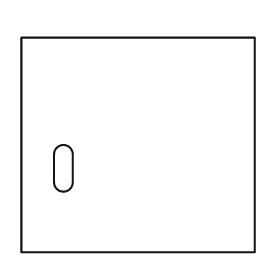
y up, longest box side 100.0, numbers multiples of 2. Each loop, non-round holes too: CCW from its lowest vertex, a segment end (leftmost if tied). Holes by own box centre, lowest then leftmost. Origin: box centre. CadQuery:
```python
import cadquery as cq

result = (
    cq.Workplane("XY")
    .moveTo(-50.0, -46.0)
    .lineTo(50.0, -46.0)
    .lineTo(50.0, 46.0)
    .lineTo(-50.0, 46.0)
    .close()
    .moveTo(-36.0, -16.0)
    .threePointArc((-32.0, -20.0), (-28.0, -16.0))
    .lineTo(-28.0, -4.0)
    .threePointArc((-32.0, 0.0), (-36.0, -4.0))
    .close()
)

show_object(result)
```